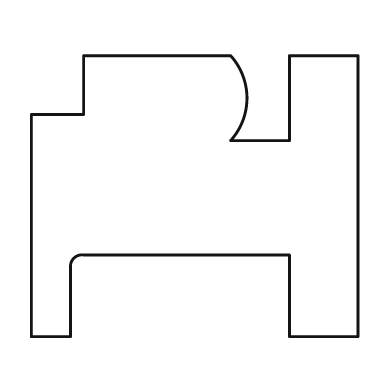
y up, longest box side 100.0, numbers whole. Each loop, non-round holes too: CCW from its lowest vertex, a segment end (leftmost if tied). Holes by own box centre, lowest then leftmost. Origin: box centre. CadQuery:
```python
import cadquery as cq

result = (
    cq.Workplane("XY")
    .moveTo(-50.0, -43.0)
    .lineTo(-38.0, -43.0)
    .lineTo(-38.0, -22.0)
    .threePointArc((-37.0, -19.0), (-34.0, -18.0))
    .lineTo(29.0, -18.0)
    .lineTo(29.0, -43.0)
    .lineTo(50.0, -43.0)
    .lineTo(50.0, 43.0)
    .lineTo(29.0, 43.0)
    .lineTo(29.0, 17.0)
    .lineTo(11.0, 17.0)
    .threePointArc((16.0, 30.0), (11.0, 43.0))
    .lineTo(-34.0, 43.0)
    .lineTo(-34.0, 25.0)
    .lineTo(-50.0, 25.0)
    .close()
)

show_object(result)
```